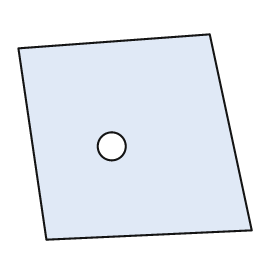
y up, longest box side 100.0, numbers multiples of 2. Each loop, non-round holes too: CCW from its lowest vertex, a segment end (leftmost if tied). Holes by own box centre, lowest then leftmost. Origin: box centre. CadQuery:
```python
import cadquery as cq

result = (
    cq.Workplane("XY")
    .moveTo(-38.0, -44.0)
    .lineTo(50.0, -40.0)
    .lineTo(32.0, 44.0)
    .lineTo(-50.0, 38.0)
    .close()
    .moveTo(-10.0, -4.0)
    .circle(6.0)
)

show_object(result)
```